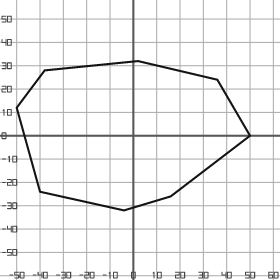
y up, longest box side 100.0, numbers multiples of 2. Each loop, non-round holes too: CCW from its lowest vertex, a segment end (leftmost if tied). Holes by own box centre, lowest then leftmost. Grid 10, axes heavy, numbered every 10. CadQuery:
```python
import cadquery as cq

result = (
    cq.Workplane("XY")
    .moveTo(-4.0, -32.0)
    .lineTo(16.0, -26.0)
    .lineTo(50.0, 0.0)
    .lineTo(36.0, 24.0)
    .lineTo(2.0, 32.0)
    .lineTo(-38.0, 28.0)
    .lineTo(-50.0, 12.0)
    .lineTo(-40.0, -24.0)
    .close()
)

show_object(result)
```